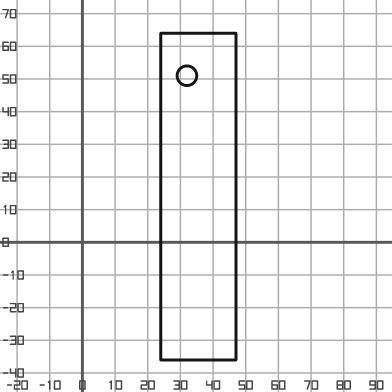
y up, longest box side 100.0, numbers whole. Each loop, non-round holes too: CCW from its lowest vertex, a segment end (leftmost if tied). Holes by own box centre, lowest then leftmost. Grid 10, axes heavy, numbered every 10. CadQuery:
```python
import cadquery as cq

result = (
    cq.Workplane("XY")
    .moveTo(24.0, -36.0)
    .lineTo(47.0, -36.0)
    .lineTo(47.0, 64.0)
    .lineTo(24.0, 64.0)
    .close()
    .moveTo(32.0, 51.0)
    .circle(3.0)
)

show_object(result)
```